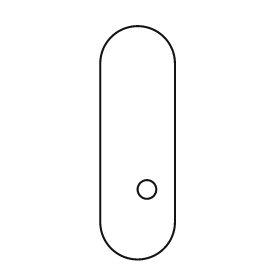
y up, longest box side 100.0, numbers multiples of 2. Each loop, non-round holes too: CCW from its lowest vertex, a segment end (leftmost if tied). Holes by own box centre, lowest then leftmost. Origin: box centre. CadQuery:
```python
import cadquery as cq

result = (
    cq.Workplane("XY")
    .moveTo(-16.0, -34.0)
    .threePointArc((0.0, -50.0), (16.0, -34.0))
    .lineTo(16.0, 34.0)
    .threePointArc((0.0, 50.0), (-16.0, 34.0))
    .close()
    .moveTo(4.0, -20.0)
    .circle(4.0)
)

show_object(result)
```